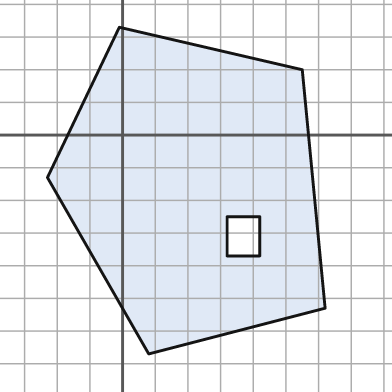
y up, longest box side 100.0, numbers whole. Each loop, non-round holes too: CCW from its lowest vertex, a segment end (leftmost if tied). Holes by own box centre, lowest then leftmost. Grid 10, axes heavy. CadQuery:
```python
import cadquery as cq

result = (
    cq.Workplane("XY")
    .moveTo(8.0, -67.0)
    .lineTo(62.0, -53.0)
    .lineTo(55.0, 20.0)
    .lineTo(-1.0, 33.0)
    .lineTo(-23.0, -13.0)
    .close()
    .moveTo(32.0, -37.0)
    .lineTo(42.0, -37.0)
    .lineTo(42.0, -25.0)
    .lineTo(32.0, -25.0)
    .close()
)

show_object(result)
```